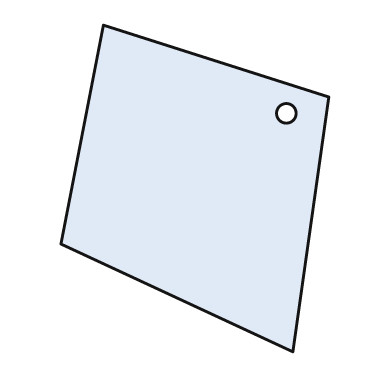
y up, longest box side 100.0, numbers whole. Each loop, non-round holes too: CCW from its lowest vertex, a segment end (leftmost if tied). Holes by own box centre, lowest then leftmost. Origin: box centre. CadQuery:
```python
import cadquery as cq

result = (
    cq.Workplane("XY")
    .moveTo(30.0, -50.0)
    .lineTo(41.0, 28.0)
    .lineTo(-28.0, 50.0)
    .lineTo(-41.0, -17.0)
    .close()
    .moveTo(28.0, 23.0)
    .circle(3.0)
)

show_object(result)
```